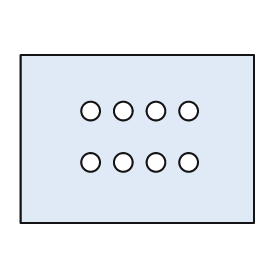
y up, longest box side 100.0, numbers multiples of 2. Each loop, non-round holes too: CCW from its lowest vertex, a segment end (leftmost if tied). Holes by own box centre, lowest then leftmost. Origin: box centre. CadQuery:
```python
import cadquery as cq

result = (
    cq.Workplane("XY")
    .moveTo(-50.0, -36.0)
    .lineTo(50.0, -36.0)
    .lineTo(50.0, 36.0)
    .lineTo(-50.0, 36.0)
    .close()
    .moveTo(-20.0, -10.0)
    .circle(4.0)
    .moveTo(-6.0, -10.0)
    .circle(4.0)
    .moveTo(8.0, -10.0)
    .circle(4.0)
    .moveTo(22.0, -10.0)
    .circle(4.0)
    .moveTo(-20.0, 12.0)
    .circle(4.0)
    .moveTo(-6.0, 12.0)
    .circle(4.0)
    .moveTo(8.0, 12.0)
    .circle(4.0)
    .moveTo(22.0, 12.0)
    .circle(4.0)
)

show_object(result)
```